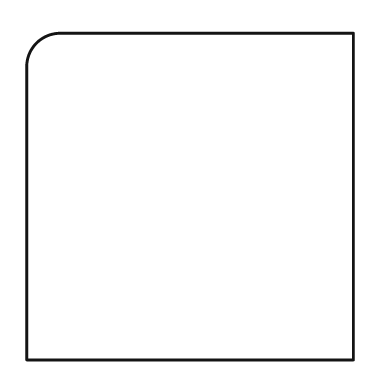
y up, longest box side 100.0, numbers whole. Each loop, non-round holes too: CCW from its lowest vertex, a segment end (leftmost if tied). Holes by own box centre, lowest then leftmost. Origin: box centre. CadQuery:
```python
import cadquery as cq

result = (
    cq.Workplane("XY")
    .moveTo(-50.0, -50.0)
    .lineTo(50.0, -50.0)
    .lineTo(50.0, 50.0)
    .lineTo(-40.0, 50.0)
    .threePointArc((-47.0, 47.0), (-50.0, 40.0))
    .close()
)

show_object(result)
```